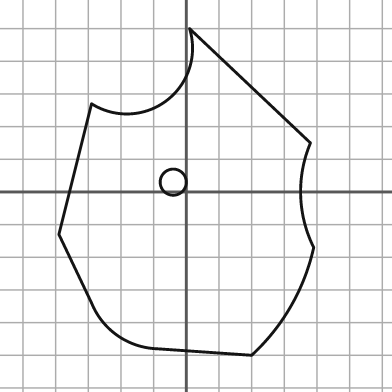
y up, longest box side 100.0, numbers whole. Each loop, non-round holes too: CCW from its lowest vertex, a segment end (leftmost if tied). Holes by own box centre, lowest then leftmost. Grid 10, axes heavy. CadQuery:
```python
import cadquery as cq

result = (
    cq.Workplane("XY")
    .moveTo(20.0, -50.0)
    .threePointArc((32.0, -35.0), (39.0, -17.0))
    .threePointArc((35.0, -1.0), (38.0, 15.0))
    .lineTo(1.0, 50.0)
    .threePointArc((-6.0, 28.0), (-29.0, 27.0))
    .lineTo(-39.0, -13.0)
    .lineTo(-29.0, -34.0)
    .threePointArc((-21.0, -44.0), (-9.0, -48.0))
    .close()
    .moveTo(-4.0, 3.0)
    .circle(4.0)
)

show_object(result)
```